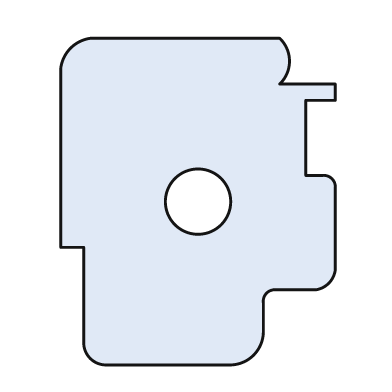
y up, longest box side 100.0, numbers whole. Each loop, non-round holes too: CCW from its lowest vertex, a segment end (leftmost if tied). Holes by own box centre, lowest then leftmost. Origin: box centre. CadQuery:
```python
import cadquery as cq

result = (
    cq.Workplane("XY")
    .moveTo(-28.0, -50.0)
    .lineTo(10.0, -50.0)
    .threePointArc((17.0, -47.0), (20.0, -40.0))
    .lineTo(20.0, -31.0)
    .threePointArc((21.0, -28.0), (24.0, -27.0))
    .lineTo(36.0, -27.0)
    .threePointArc((40.0, -25.0), (42.0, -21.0))
    .lineTo(42.0, 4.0)
    .threePointArc((41.0, 7.0), (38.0, 8.0))
    .lineTo(33.0, 8.0)
    .lineTo(33.0, 31.0)
    .lineTo(42.0, 31.0)
    .lineTo(42.0, 36.0)
    .lineTo(25.0, 36.0)
    .threePointArc((28.0, 43.0), (25.0, 50.0))
    .lineTo(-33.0, 50.0)
    .threePointArc((-39.0, 47.0), (-42.0, 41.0))
    .lineTo(-42.0, -14.0)
    .lineTo(-35.0, -14.0)
    .lineTo(-35.0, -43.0)
    .threePointArc((-33.0, -48.0), (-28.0, -50.0))
    .close()
    .moveTo(0.0, 0.0)
    .circle(10.0)
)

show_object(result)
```